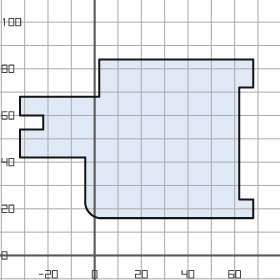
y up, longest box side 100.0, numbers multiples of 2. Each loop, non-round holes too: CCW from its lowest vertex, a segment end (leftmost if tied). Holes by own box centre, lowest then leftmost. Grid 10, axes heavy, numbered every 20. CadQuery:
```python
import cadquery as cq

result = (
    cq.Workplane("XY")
    .moveTo(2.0, 16.0)
    .lineTo(68.0, 16.0)
    .lineTo(68.0, 24.0)
    .lineTo(62.0, 24.0)
    .lineTo(62.0, 72.0)
    .lineTo(68.0, 72.0)
    .lineTo(68.0, 84.0)
    .lineTo(2.0, 84.0)
    .lineTo(2.0, 68.0)
    .lineTo(-32.0, 68.0)
    .lineTo(-32.0, 60.0)
    .lineTo(-22.0, 60.0)
    .lineTo(-22.0, 54.0)
    .lineTo(-32.0, 54.0)
    .lineTo(-32.0, 42.0)
    .lineTo(-4.0, 42.0)
    .lineTo(-4.0, 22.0)
    .threePointArc((-2.0, 18.0), (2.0, 16.0))
    .close()
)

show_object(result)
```